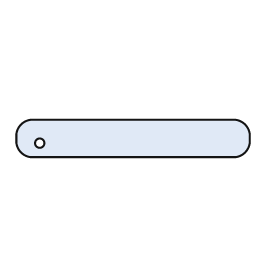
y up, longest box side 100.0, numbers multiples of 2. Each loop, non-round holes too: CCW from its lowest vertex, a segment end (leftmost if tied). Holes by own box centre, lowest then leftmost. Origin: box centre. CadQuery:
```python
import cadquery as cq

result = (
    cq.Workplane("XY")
    .moveTo(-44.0, -8.0)
    .lineTo(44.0, -8.0)
    .threePointArc((48.0, -6.0), (50.0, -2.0))
    .lineTo(50.0, 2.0)
    .threePointArc((48.0, 6.0), (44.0, 8.0))
    .lineTo(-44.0, 8.0)
    .threePointArc((-48.0, 6.0), (-50.0, 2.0))
    .lineTo(-50.0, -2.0)
    .threePointArc((-48.0, -6.0), (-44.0, -8.0))
    .close()
    .moveTo(-40.0, -2.0)
    .circle(2.0)
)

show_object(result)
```